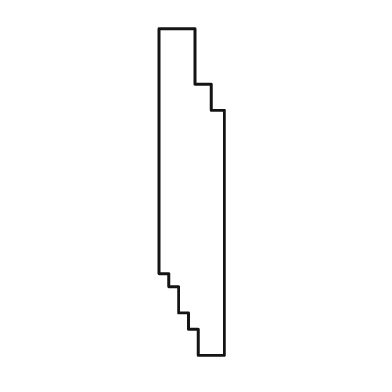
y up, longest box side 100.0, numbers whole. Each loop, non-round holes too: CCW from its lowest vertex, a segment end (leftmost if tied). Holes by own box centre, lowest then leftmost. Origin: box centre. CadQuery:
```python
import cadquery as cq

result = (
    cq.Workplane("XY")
    .moveTo(2.0, -50.0)
    .lineTo(10.0, -50.0)
    .lineTo(10.0, 25.0)
    .lineTo(6.0, 25.0)
    .lineTo(6.0, 33.0)
    .lineTo(1.0, 33.0)
    .lineTo(1.0, 50.0)
    .lineTo(-10.0, 50.0)
    .lineTo(-10.0, -25.0)
    .lineTo(-7.0, -25.0)
    .lineTo(-7.0, -29.0)
    .lineTo(-4.0, -29.0)
    .lineTo(-4.0, -37.0)
    .lineTo(-1.0, -37.0)
    .lineTo(-1.0, -42.0)
    .lineTo(2.0, -42.0)
    .close()
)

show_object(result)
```